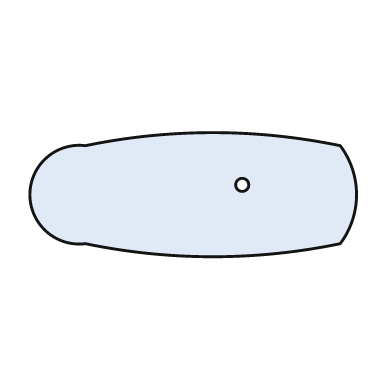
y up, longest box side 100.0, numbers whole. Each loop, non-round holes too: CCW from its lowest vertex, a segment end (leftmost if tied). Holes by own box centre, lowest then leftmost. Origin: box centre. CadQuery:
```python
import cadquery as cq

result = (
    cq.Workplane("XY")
    .moveTo(-33.0, -15.0)
    .threePointArc((6.0, -19.0), (45.0, -15.0))
    .threePointArc((50.0, 0.0), (45.0, 15.0))
    .threePointArc((6.0, 19.0), (-33.0, 15.0))
    .threePointArc((-50.0, 0.0), (-33.0, -15.0))
    .close()
    .moveTo(15.0, 3.0)
    .circle(2.0)
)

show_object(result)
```